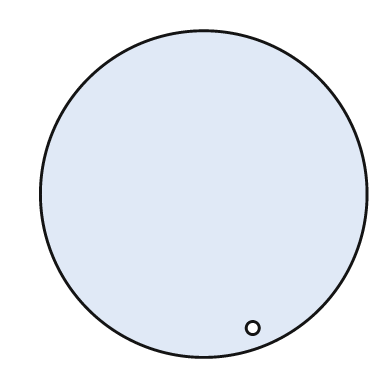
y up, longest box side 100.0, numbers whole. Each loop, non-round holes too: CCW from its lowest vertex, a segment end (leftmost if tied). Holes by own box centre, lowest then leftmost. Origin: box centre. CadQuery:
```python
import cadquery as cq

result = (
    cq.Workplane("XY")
    .moveTo(0.0, 0.0)
    .circle(50.0)
    .moveTo(15.0, -41.0)
    .circle(2.0)
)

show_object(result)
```